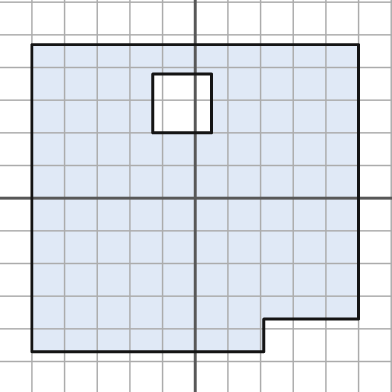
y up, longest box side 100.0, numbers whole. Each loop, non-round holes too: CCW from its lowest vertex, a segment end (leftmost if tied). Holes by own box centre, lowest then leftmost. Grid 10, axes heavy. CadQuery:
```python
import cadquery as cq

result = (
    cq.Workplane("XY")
    .moveTo(-50.0, -47.0)
    .lineTo(21.0, -47.0)
    .lineTo(21.0, -37.0)
    .lineTo(50.0, -37.0)
    .lineTo(50.0, 47.0)
    .lineTo(-50.0, 47.0)
    .close()
    .moveTo(-13.0, 20.0)
    .lineTo(5.0, 20.0)
    .lineTo(5.0, 38.0)
    .lineTo(-13.0, 38.0)
    .close()
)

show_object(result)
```